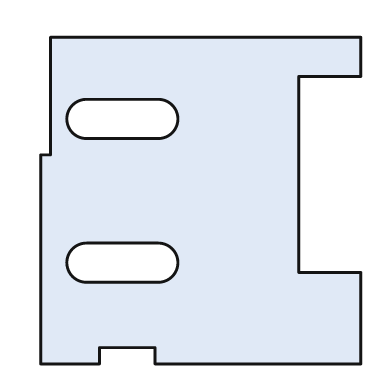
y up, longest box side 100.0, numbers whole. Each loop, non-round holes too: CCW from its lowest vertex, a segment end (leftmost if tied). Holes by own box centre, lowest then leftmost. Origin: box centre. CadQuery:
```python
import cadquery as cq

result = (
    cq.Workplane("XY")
    .moveTo(-49.0, -50.0)
    .lineTo(-31.0, -50.0)
    .lineTo(-31.0, -45.0)
    .lineTo(-14.0, -45.0)
    .lineTo(-14.0, -50.0)
    .lineTo(49.0, -50.0)
    .lineTo(49.0, -22.0)
    .lineTo(30.0, -22.0)
    .lineTo(30.0, 38.0)
    .lineTo(49.0, 38.0)
    .lineTo(49.0, 50.0)
    .lineTo(-46.0, 50.0)
    .lineTo(-46.0, 14.0)
    .lineTo(-49.0, 14.0)
    .close()
    .moveTo(-35.0, -25.0)
    .lineTo(-13.0, -25.0)
    .threePointArc((-7.0, -19.0), (-13.0, -13.0))
    .lineTo(-35.0, -13.0)
    .threePointArc((-41.0, -19.0), (-35.0, -25.0))
    .close()
    .moveTo(-35.0, 19.0)
    .lineTo(-13.0, 19.0)
    .threePointArc((-7.0, 25.0), (-13.0, 31.0))
    .lineTo(-35.0, 31.0)
    .threePointArc((-41.0, 25.0), (-35.0, 19.0))
    .close()
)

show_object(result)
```